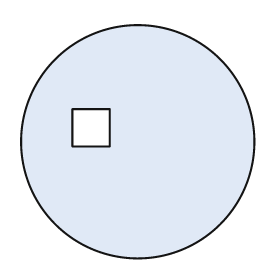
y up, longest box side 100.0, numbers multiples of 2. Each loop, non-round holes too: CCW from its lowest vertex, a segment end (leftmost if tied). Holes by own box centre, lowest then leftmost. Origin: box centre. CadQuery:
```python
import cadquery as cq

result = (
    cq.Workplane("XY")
    .moveTo(0.0, 0.0)
    .circle(50.0)
    .moveTo(-28.0, -2.0)
    .lineTo(-12.0, -2.0)
    .lineTo(-12.0, 14.0)
    .lineTo(-28.0, 14.0)
    .close()
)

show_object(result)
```